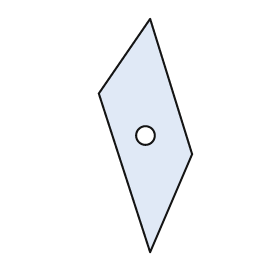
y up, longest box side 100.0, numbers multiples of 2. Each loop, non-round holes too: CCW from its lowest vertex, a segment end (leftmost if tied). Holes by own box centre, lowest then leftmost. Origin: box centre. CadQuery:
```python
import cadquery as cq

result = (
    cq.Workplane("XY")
    .moveTo(2.0, -50.0)
    .lineTo(20.0, -8.0)
    .lineTo(2.0, 50.0)
    .lineTo(-20.0, 18.0)
    .close()
    .moveTo(0.0, 0.0)
    .circle(4.0)
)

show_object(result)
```